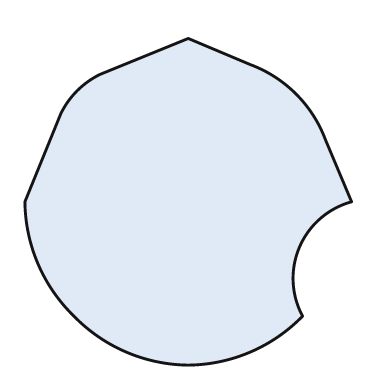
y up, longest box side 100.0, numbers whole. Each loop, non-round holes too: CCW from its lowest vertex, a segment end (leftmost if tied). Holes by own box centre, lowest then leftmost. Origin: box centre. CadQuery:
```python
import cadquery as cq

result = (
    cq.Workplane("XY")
    .moveTo(0.0, -50.0)
    .threePointArc((19.0, -46.0), (35.0, -35.0))
    .threePointArc((34.0, -14.0), (50.0, 0.0))
    .lineTo(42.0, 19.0)
    .threePointArc((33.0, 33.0), (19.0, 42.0))
    .lineTo(0.0, 50.0)
    .lineTo(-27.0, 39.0)
    .threePointArc((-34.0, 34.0), (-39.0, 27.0))
    .lineTo(-50.0, 0.0)
    .threePointArc((-46.0, -19.0), (-35.0, -35.0))
    .threePointArc((-19.0, -46.0), (0.0, -50.0))
    .close()
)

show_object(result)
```